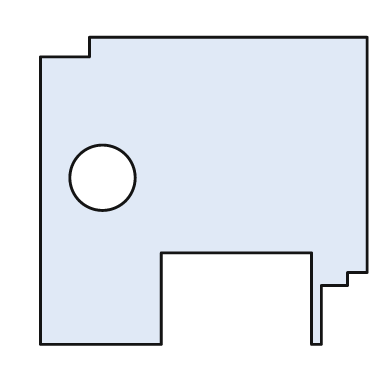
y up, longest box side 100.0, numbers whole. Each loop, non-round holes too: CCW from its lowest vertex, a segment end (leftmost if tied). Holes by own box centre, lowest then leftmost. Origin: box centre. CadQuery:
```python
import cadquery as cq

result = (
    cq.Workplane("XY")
    .moveTo(-50.0, -47.0)
    .lineTo(-13.0, -47.0)
    .lineTo(-13.0, -19.0)
    .lineTo(33.0, -19.0)
    .lineTo(33.0, -47.0)
    .lineTo(36.0, -47.0)
    .lineTo(36.0, -29.0)
    .lineTo(44.0, -29.0)
    .lineTo(44.0, -25.0)
    .lineTo(50.0, -25.0)
    .lineTo(50.0, 47.0)
    .lineTo(-35.0, 47.0)
    .lineTo(-35.0, 41.0)
    .lineTo(-50.0, 41.0)
    .close()
    .moveTo(-31.0, 4.0)
    .circle(10.0)
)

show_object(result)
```